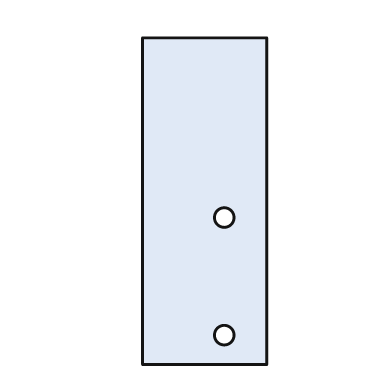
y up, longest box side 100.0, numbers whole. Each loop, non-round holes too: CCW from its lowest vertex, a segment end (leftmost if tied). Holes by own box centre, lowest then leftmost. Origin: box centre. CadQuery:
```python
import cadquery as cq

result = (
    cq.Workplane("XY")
    .moveTo(-19.0, -50.0)
    .lineTo(19.0, -50.0)
    .lineTo(19.0, 50.0)
    .lineTo(-19.0, 50.0)
    .close()
    .moveTo(6.0, -41.0)
    .circle(3.0)
    .moveTo(6.0, -5.0)
    .circle(3.0)
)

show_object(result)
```